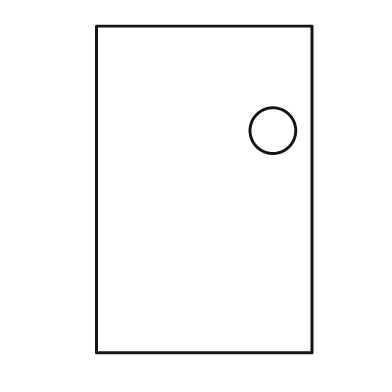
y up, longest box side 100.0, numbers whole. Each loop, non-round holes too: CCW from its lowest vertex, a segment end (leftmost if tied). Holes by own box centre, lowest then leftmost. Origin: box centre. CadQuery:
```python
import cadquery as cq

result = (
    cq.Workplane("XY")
    .moveTo(-33.0, -50.0)
    .lineTo(33.0, -50.0)
    .lineTo(33.0, 50.0)
    .lineTo(-33.0, 50.0)
    .close()
    .moveTo(21.0, 18.0)
    .circle(7.0)
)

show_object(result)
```